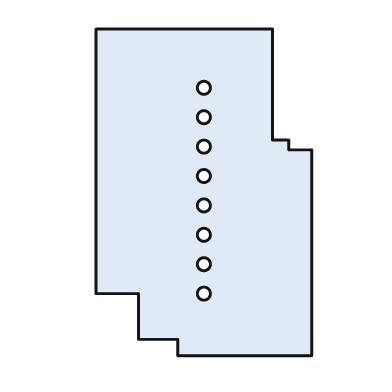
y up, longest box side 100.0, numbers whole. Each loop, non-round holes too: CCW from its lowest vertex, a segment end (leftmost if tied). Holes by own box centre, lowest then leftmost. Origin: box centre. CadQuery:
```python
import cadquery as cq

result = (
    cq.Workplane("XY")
    .moveTo(-8.0, -50.0)
    .lineTo(33.0, -50.0)
    .lineTo(33.0, 13.0)
    .lineTo(26.0, 13.0)
    .lineTo(26.0, 16.0)
    .lineTo(21.0, 16.0)
    .lineTo(21.0, 50.0)
    .lineTo(-33.0, 50.0)
    .lineTo(-33.0, -31.0)
    .lineTo(-20.0, -31.0)
    .lineTo(-20.0, -45.0)
    .lineTo(-8.0, -45.0)
    .close()
    .moveTo(0.0, -31.0)
    .circle(2.0)
    .moveTo(0.0, -22.0)
    .circle(2.0)
    .moveTo(0.0, -13.0)
    .circle(2.0)
    .moveTo(0.0, -4.0)
    .circle(2.0)
    .moveTo(0.0, 5.0)
    .circle(2.0)
    .moveTo(0.0, 14.0)
    .circle(2.0)
    .moveTo(0.0, 23.0)
    .circle(2.0)
    .moveTo(0.0, 32.0)
    .circle(2.0)
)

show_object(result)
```